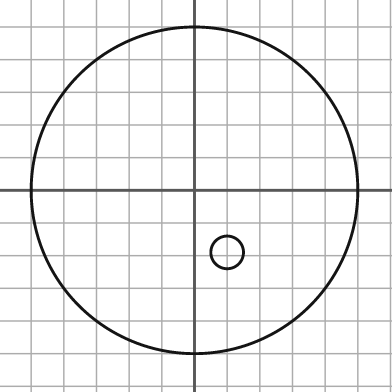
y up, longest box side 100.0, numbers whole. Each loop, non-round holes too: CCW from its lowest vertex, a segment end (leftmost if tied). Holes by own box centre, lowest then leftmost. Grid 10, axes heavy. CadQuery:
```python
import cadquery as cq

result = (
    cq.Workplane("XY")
    .moveTo(0.0, 0.0)
    .circle(50.0)
    .moveTo(10.0, -19.0)
    .circle(5.0)
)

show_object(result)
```